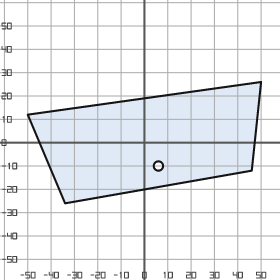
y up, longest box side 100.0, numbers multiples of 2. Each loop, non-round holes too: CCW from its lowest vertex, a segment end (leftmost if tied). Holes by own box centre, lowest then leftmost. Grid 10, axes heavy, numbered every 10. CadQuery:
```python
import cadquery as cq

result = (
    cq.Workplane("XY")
    .moveTo(-34.0, -26.0)
    .lineTo(46.0, -12.0)
    .lineTo(50.0, 26.0)
    .lineTo(-50.0, 12.0)
    .close()
    .moveTo(6.0, -10.0)
    .circle(2.0)
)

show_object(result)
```